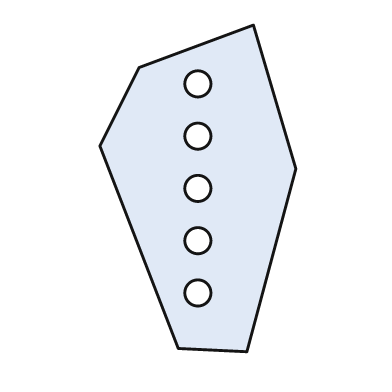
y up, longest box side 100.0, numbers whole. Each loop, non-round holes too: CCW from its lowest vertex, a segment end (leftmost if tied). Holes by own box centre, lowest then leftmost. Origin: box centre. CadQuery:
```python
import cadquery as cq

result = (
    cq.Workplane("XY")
    .moveTo(15.0, -50.0)
    .lineTo(30.0, 6.0)
    .lineTo(17.0, 50.0)
    .lineTo(-18.0, 37.0)
    .lineTo(-30.0, 13.0)
    .lineTo(-6.0, -49.0)
    .close()
    .moveTo(0.0, -32.0)
    .circle(4.0)
    .moveTo(0.0, -16.0)
    .circle(4.0)
    .moveTo(0.0, 0.0)
    .circle(4.0)
    .moveTo(0.0, 16.0)
    .circle(4.0)
    .moveTo(0.0, 32.0)
    .circle(4.0)
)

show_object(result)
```